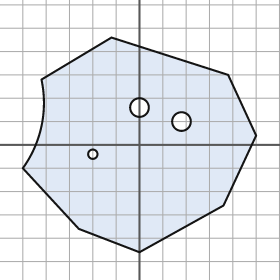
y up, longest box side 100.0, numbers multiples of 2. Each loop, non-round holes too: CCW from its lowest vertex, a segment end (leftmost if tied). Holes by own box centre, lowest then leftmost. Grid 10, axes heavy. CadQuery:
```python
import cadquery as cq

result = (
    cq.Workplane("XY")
    .moveTo(0.0, -46.0)
    .lineTo(36.0, -26.0)
    .lineTo(50.0, 4.0)
    .lineTo(38.0, 30.0)
    .lineTo(-12.0, 46.0)
    .lineTo(-42.0, 28.0)
    .threePointArc((-42.0, 8.0), (-50.0, -10.0))
    .lineTo(-26.0, -36.0)
    .close()
    .moveTo(-20.0, -4.0)
    .circle(2.0)
    .moveTo(18.0, 10.0)
    .circle(4.0)
    .moveTo(0.0, 16.0)
    .circle(4.0)
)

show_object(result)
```